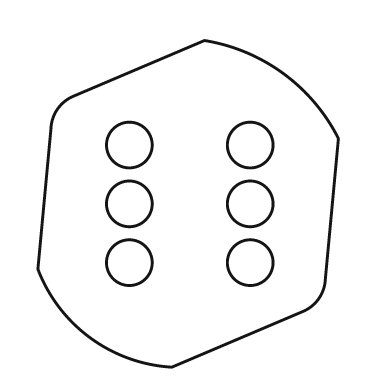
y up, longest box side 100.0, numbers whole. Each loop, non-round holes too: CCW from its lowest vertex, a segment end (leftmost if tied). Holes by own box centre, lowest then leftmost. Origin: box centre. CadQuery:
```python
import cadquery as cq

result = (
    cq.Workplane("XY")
    .moveTo(-5.0, -50.0)
    .lineTo(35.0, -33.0)
    .threePointArc((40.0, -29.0), (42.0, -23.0))
    .lineTo(46.0, 20.0)
    .threePointArc((29.0, 40.0), (5.0, 50.0))
    .lineTo(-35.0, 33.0)
    .threePointArc((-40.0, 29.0), (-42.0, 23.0))
    .lineTo(-46.0, -20.0)
    .threePointArc((-30.0, -41.0), (-5.0, -50.0))
    .close()
    .moveTo(-18.0, -18.0)
    .circle(7.0)
    .moveTo(19.0, -18.0)
    .circle(7.0)
    .moveTo(-18.0, 0.0)
    .circle(7.0)
    .moveTo(19.0, 0.0)
    .circle(7.0)
    .moveTo(-18.0, 18.0)
    .circle(7.0)
    .moveTo(19.0, 18.0)
    .circle(7.0)
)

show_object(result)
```